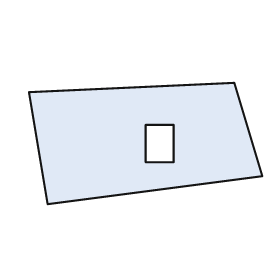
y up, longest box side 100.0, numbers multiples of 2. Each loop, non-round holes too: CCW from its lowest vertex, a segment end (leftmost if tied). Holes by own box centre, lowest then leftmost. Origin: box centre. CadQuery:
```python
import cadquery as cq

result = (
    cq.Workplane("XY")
    .moveTo(-42.0, -26.0)
    .lineTo(50.0, -14.0)
    .lineTo(38.0, 26.0)
    .lineTo(-50.0, 22.0)
    .close()
    .moveTo(0.0, -8.0)
    .lineTo(12.0, -8.0)
    .lineTo(12.0, 8.0)
    .lineTo(0.0, 8.0)
    .close()
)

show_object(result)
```